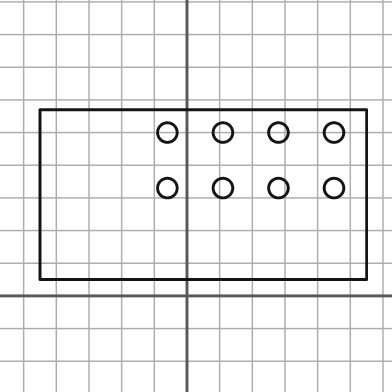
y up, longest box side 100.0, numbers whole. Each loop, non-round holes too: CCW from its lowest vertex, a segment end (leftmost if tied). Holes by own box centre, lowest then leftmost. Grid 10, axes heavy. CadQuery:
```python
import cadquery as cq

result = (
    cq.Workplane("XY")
    .moveTo(-45.0, 5.0)
    .lineTo(55.0, 5.0)
    .lineTo(55.0, 57.0)
    .lineTo(-45.0, 57.0)
    .close()
    .moveTo(-6.0, 33.0)
    .circle(3.0)
    .moveTo(11.0, 33.0)
    .circle(3.0)
    .moveTo(28.0, 33.0)
    .circle(3.0)
    .moveTo(45.0, 33.0)
    .circle(3.0)
    .moveTo(-6.0, 50.0)
    .circle(3.0)
    .moveTo(11.0, 50.0)
    .circle(3.0)
    .moveTo(28.0, 50.0)
    .circle(3.0)
    .moveTo(45.0, 50.0)
    .circle(3.0)
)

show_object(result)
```